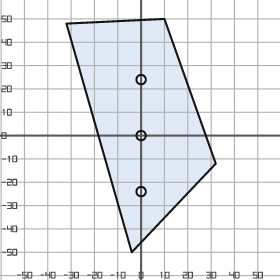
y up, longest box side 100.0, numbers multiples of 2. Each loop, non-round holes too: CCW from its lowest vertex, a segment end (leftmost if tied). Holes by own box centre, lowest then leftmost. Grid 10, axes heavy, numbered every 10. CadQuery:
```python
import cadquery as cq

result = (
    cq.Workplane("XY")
    .moveTo(-4.0, -50.0)
    .lineTo(32.0, -12.0)
    .lineTo(10.0, 50.0)
    .lineTo(-32.0, 48.0)
    .close()
    .moveTo(0.0, -24.0)
    .circle(2.0)
    .moveTo(0.0, 0.0)
    .circle(2.0)
    .moveTo(0.0, 24.0)
    .circle(2.0)
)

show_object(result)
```